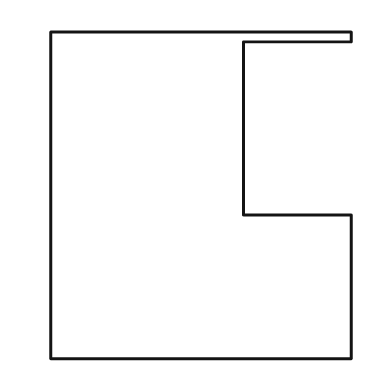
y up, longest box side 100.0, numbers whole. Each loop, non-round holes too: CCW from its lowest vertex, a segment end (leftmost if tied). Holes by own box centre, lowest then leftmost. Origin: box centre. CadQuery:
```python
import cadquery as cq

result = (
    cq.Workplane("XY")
    .moveTo(-46.0, -50.0)
    .lineTo(46.0, -50.0)
    .lineTo(46.0, -6.0)
    .lineTo(13.0, -6.0)
    .lineTo(13.0, 47.0)
    .lineTo(46.0, 47.0)
    .lineTo(46.0, 50.0)
    .lineTo(-46.0, 50.0)
    .close()
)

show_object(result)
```